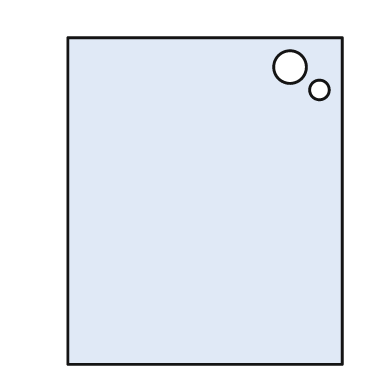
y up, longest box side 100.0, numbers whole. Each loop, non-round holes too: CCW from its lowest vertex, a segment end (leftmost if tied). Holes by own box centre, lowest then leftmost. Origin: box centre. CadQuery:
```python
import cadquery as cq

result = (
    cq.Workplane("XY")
    .moveTo(-42.0, -50.0)
    .lineTo(42.0, -50.0)
    .lineTo(42.0, 50.0)
    .lineTo(-42.0, 50.0)
    .close()
    .moveTo(35.0, 34.0)
    .circle(3.0)
    .moveTo(26.0, 41.0)
    .circle(5.0)
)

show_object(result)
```